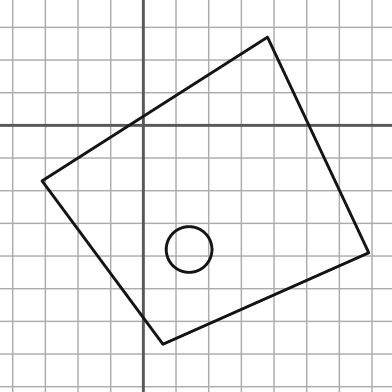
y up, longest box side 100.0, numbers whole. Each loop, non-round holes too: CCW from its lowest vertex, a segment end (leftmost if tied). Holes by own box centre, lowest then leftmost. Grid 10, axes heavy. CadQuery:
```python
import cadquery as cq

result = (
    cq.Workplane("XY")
    .moveTo(6.0, -67.0)
    .lineTo(69.0, -39.0)
    .lineTo(38.0, 27.0)
    .lineTo(-31.0, -17.0)
    .close()
    .moveTo(14.0, -38.0)
    .circle(7.0)
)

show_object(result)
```